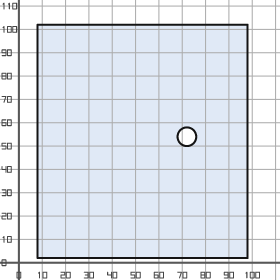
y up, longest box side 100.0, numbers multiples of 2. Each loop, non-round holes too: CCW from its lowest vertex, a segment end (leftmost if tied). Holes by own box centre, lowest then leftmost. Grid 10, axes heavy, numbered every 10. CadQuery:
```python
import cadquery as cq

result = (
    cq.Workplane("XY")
    .moveTo(8.0, 2.0)
    .lineTo(98.0, 2.0)
    .lineTo(98.0, 102.0)
    .lineTo(8.0, 102.0)
    .close()
    .moveTo(72.0, 54.0)
    .circle(4.0)
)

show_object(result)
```